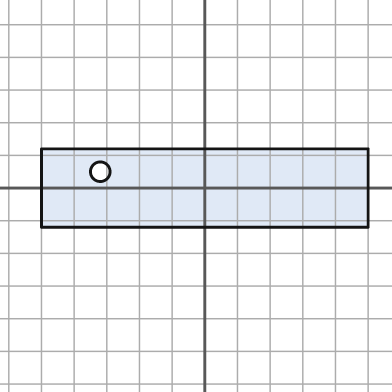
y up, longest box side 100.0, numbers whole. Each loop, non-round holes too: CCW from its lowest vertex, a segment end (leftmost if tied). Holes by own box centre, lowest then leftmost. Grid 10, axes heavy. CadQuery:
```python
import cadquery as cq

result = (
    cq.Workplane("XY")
    .moveTo(-50.0, -12.0)
    .lineTo(50.0, -12.0)
    .lineTo(50.0, 12.0)
    .lineTo(-50.0, 12.0)
    .close()
    .moveTo(-32.0, 5.0)
    .circle(3.0)
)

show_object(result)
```